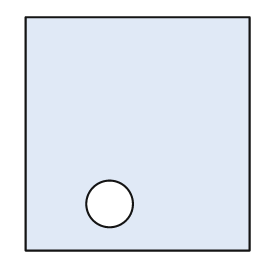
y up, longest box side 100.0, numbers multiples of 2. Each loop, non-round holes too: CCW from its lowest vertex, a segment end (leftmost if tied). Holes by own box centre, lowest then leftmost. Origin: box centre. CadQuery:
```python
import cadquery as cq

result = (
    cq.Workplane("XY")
    .moveTo(-48.0, -50.0)
    .lineTo(48.0, -50.0)
    .lineTo(48.0, 50.0)
    .lineTo(-48.0, 50.0)
    .close()
    .moveTo(-12.0, -30.0)
    .circle(10.0)
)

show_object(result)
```